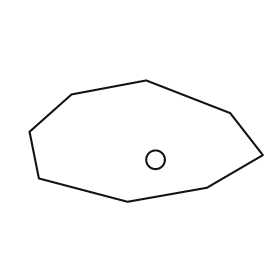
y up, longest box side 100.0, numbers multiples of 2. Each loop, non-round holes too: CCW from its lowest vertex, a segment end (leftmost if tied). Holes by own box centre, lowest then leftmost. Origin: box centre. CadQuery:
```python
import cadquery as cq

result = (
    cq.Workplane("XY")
    .moveTo(-8.0, -26.0)
    .lineTo(26.0, -20.0)
    .lineTo(50.0, -6.0)
    .lineTo(36.0, 12.0)
    .lineTo(0.0, 26.0)
    .lineTo(-32.0, 20.0)
    .lineTo(-50.0, 4.0)
    .lineTo(-46.0, -16.0)
    .close()
    .moveTo(4.0, -8.0)
    .circle(4.0)
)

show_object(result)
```